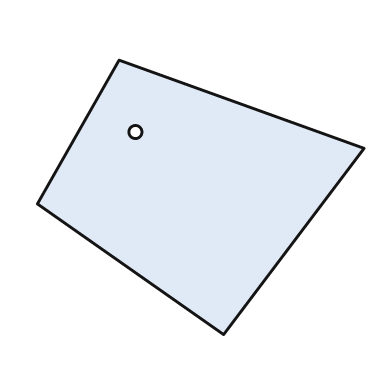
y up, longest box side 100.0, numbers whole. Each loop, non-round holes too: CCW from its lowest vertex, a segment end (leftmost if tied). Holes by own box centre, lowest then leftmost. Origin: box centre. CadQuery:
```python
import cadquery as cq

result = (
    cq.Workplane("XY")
    .moveTo(7.0, -42.0)
    .lineTo(50.0, 15.0)
    .lineTo(-25.0, 42.0)
    .lineTo(-50.0, -2.0)
    .close()
    .moveTo(-20.0, 20.0)
    .circle(2.0)
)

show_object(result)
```